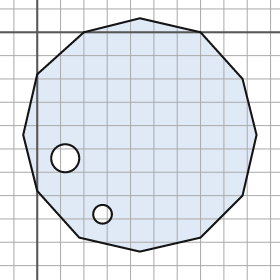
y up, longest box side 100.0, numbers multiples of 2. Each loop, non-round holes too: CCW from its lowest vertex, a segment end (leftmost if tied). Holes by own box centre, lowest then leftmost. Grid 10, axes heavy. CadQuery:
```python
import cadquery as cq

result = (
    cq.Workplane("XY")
    .moveTo(44.0, -94.0)
    .lineTo(70.0, -88.0)
    .lineTo(88.0, -70.0)
    .lineTo(94.0, -44.0)
    .lineTo(88.0, -20.0)
    .lineTo(70.0, 0.0)
    .lineTo(44.0, 6.0)
    .lineTo(20.0, 0.0)
    .lineTo(0.0, -18.0)
    .lineTo(-6.0, -44.0)
    .lineTo(0.0, -68.0)
    .lineTo(18.0, -88.0)
    .close()
    .moveTo(28.0, -78.0)
    .circle(4.0)
    .moveTo(12.0, -54.0)
    .circle(6.0)
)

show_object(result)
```